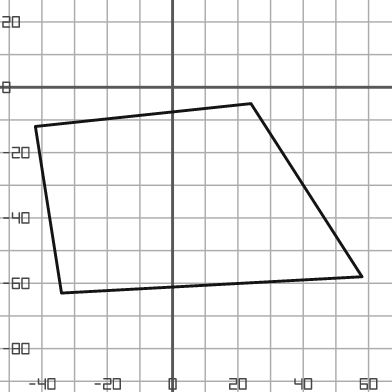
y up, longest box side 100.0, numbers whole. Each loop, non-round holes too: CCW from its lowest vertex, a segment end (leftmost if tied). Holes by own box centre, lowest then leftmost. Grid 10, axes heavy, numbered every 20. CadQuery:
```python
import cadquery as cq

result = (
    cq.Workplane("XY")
    .moveTo(-34.0, -63.0)
    .lineTo(58.0, -58.0)
    .lineTo(24.0, -5.0)
    .lineTo(-42.0, -12.0)
    .close()
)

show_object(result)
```